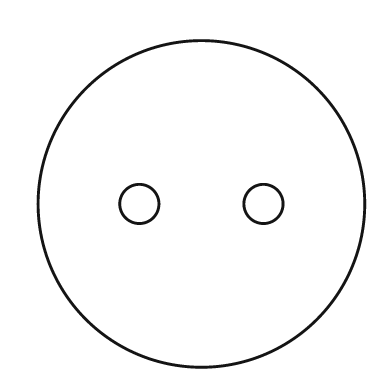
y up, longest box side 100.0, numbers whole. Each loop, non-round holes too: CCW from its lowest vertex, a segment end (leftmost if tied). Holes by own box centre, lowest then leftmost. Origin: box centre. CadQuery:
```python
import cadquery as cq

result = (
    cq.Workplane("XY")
    .moveTo(0.0, 0.0)
    .circle(50.0)
    .moveTo(-19.0, 0.0)
    .circle(6.0)
    .moveTo(19.0, 0.0)
    .circle(6.0)
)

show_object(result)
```